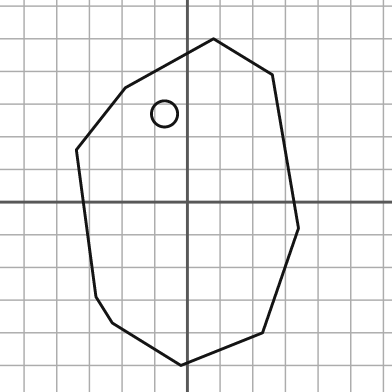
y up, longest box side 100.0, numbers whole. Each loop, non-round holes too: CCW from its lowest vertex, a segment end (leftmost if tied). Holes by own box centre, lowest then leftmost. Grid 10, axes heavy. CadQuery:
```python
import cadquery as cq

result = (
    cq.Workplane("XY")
    .moveTo(-2.0, -50.0)
    .lineTo(23.0, -40.0)
    .lineTo(34.0, -8.0)
    .lineTo(26.0, 39.0)
    .lineTo(8.0, 50.0)
    .lineTo(-19.0, 35.0)
    .lineTo(-34.0, 16.0)
    .lineTo(-28.0, -29.0)
    .lineTo(-23.0, -37.0)
    .close()
    .moveTo(-7.0, 27.0)
    .circle(4.0)
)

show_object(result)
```